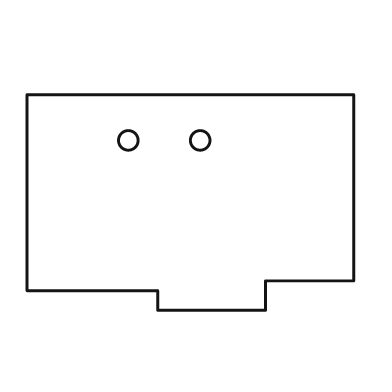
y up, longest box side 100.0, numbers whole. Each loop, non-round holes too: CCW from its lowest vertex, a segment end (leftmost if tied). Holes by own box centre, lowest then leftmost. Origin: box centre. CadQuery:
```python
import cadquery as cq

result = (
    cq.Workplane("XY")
    .moveTo(-10.0, -33.0)
    .lineTo(23.0, -33.0)
    .lineTo(23.0, -24.0)
    .lineTo(50.0, -24.0)
    .lineTo(50.0, 33.0)
    .lineTo(-50.0, 33.0)
    .lineTo(-50.0, -27.0)
    .lineTo(-10.0, -27.0)
    .close()
    .moveTo(-19.0, 19.0)
    .circle(3.0)
    .moveTo(3.0, 19.0)
    .circle(3.0)
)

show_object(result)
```